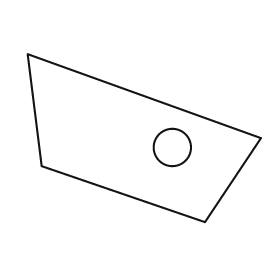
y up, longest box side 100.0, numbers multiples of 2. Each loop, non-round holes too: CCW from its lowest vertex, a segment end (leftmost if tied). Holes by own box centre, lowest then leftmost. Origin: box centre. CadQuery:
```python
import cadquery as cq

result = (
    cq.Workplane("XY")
    .moveTo(26.0, -36.0)
    .lineTo(50.0, 0.0)
    .lineTo(-50.0, 36.0)
    .lineTo(-44.0, -12.0)
    .close()
    .moveTo(12.0, -4.0)
    .circle(8.0)
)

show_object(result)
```